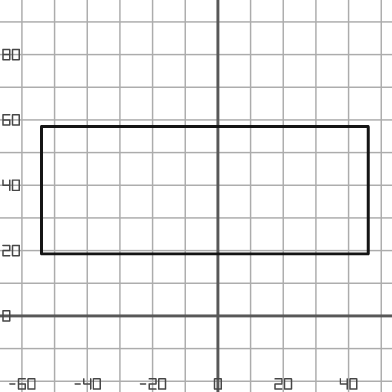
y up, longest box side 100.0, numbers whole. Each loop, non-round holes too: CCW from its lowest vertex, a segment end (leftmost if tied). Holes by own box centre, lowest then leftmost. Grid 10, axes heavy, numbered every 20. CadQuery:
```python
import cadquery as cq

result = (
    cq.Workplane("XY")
    .moveTo(-54.0, 19.0)
    .lineTo(46.0, 19.0)
    .lineTo(46.0, 58.0)
    .lineTo(-54.0, 58.0)
    .close()
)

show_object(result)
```